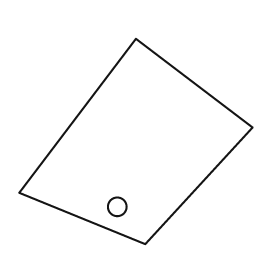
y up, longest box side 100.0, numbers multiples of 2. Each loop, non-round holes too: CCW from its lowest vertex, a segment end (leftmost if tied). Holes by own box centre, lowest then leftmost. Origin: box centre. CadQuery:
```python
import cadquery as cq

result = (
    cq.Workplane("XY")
    .moveTo(4.0, -44.0)
    .lineTo(50.0, 6.0)
    .lineTo(0.0, 44.0)
    .lineTo(-50.0, -22.0)
    .close()
    .moveTo(-8.0, -28.0)
    .circle(4.0)
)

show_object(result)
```